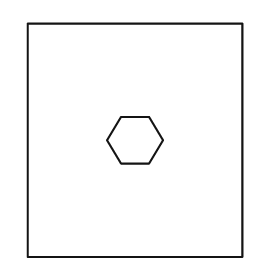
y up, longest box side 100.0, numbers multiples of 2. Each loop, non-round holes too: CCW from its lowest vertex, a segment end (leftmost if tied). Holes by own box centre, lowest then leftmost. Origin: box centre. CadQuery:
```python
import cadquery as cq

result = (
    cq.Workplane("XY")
    .moveTo(-46.0, -50.0)
    .lineTo(46.0, -50.0)
    .lineTo(46.0, 50.0)
    .lineTo(-46.0, 50.0)
    .close()
    .moveTo(-6.0, -10.0)
    .lineTo(6.0, -10.0)
    .lineTo(12.0, 0.0)
    .lineTo(6.0, 10.0)
    .lineTo(-6.0, 10.0)
    .lineTo(-12.0, 0.0)
    .close()
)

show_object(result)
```